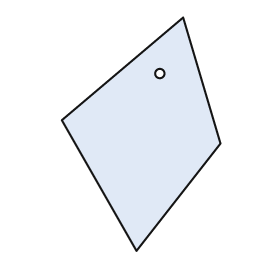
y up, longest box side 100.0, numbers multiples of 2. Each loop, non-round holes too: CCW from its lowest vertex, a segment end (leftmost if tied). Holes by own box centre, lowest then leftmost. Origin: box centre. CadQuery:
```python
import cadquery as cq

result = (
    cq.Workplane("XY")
    .moveTo(-2.0, -50.0)
    .lineTo(34.0, -4.0)
    .lineTo(18.0, 50.0)
    .lineTo(-34.0, 6.0)
    .close()
    .moveTo(8.0, 26.0)
    .circle(2.0)
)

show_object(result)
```